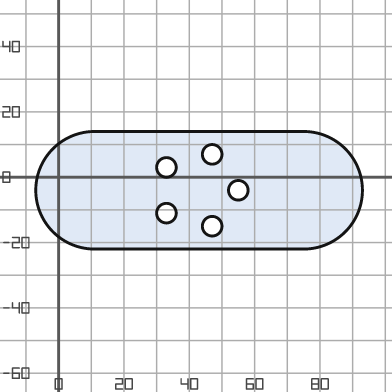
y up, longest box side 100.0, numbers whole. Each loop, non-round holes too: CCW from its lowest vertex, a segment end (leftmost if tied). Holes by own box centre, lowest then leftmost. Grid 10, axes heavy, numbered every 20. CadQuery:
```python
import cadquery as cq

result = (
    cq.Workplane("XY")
    .moveTo(11.0, -22.0)
    .lineTo(75.0, -22.0)
    .threePointArc((93.0, -4.0), (75.0, 14.0))
    .lineTo(11.0, 14.0)
    .threePointArc((-7.0, -4.0), (11.0, -22.0))
    .close()
    .moveTo(47.0, -15.0)
    .circle(3.0)
    .moveTo(33.0, -11.0)
    .circle(3.0)
    .moveTo(55.0, -4.0)
    .circle(3.0)
    .moveTo(33.0, 3.0)
    .circle(3.0)
    .moveTo(47.0, 7.0)
    .circle(3.0)
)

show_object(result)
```